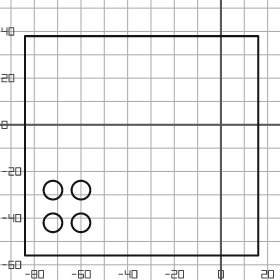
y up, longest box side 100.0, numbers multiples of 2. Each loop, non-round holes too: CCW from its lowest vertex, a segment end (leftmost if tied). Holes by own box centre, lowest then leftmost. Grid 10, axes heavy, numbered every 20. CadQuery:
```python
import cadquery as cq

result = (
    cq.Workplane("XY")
    .moveTo(-84.0, -56.0)
    .lineTo(16.0, -56.0)
    .lineTo(16.0, 38.0)
    .lineTo(-84.0, 38.0)
    .close()
    .moveTo(-72.0, -42.0)
    .circle(4.0)
    .moveTo(-60.0, -42.0)
    .circle(4.0)
    .moveTo(-72.0, -28.0)
    .circle(4.0)
    .moveTo(-60.0, -28.0)
    .circle(4.0)
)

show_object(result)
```